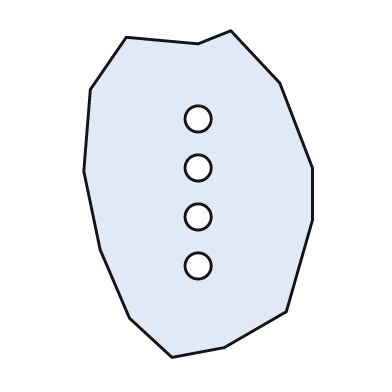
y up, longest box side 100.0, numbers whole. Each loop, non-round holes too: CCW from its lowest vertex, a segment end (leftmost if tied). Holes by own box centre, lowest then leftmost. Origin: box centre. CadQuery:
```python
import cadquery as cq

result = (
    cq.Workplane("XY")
    .moveTo(-8.0, -50.0)
    .lineTo(8.0, -47.0)
    .lineTo(27.0, -36.0)
    .lineTo(35.0, -8.0)
    .lineTo(35.0, 8.0)
    .lineTo(25.0, 34.0)
    .lineTo(10.0, 50.0)
    .lineTo(0.0, 46.0)
    .lineTo(-22.0, 48.0)
    .lineTo(-33.0, 32.0)
    .lineTo(-35.0, 7.0)
    .lineTo(-30.0, -17.0)
    .lineTo(-21.0, -38.0)
    .close()
    .moveTo(0.0, -22.0)
    .circle(4.0)
    .moveTo(0.0, -7.0)
    .circle(4.0)
    .moveTo(0.0, 8.0)
    .circle(4.0)
    .moveTo(0.0, 23.0)
    .circle(4.0)
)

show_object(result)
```